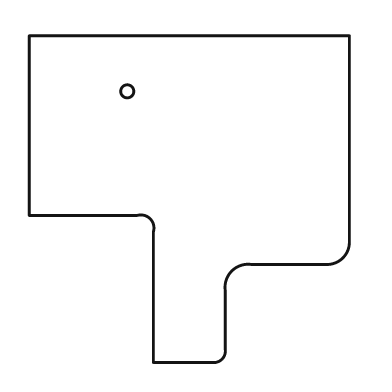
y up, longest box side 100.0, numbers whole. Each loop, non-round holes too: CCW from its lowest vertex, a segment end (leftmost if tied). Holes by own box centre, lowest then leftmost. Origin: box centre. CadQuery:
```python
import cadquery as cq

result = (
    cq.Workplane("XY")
    .moveTo(-11.0, -50.0)
    .lineTo(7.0, -50.0)
    .threePointArc((10.0, -49.0), (11.0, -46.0))
    .lineTo(11.0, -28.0)
    .threePointArc((13.0, -22.0), (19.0, -20.0))
    .lineTo(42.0, -20.0)
    .threePointArc((47.0, -18.0), (49.0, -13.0))
    .lineTo(49.0, 50.0)
    .lineTo(-49.0, 50.0)
    .lineTo(-49.0, -5.0)
    .lineTo(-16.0, -5.0)
    .threePointArc((-12.0, -6.0), (-11.0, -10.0))
    .close()
    .moveTo(-19.0, 33.0)
    .circle(2.0)
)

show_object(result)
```